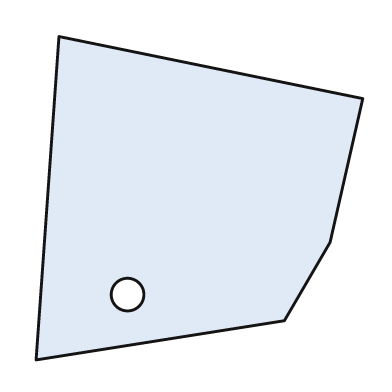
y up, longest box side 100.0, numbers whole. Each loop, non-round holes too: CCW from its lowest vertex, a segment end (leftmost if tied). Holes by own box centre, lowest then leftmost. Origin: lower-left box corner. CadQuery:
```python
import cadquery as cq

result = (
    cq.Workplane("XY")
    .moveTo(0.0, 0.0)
    .lineTo(76.0, 12.0)
    .lineTo(90.0, 36.0)
    .lineTo(100.0, 80.0)
    .lineTo(7.0, 99.0)
    .close()
    .moveTo(28.0, 20.0)
    .circle(5.0)
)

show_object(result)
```